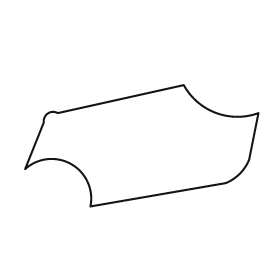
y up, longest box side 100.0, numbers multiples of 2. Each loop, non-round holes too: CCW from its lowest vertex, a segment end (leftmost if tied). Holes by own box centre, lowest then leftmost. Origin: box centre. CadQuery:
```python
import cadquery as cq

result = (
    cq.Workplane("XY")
    .moveTo(-22.0, -26.0)
    .lineTo(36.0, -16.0)
    .threePointArc((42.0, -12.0), (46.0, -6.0))
    .lineTo(50.0, 14.0)
    .threePointArc((32.0, 14.0), (18.0, 26.0))
    .lineTo(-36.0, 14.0)
    .threePointArc((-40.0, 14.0), (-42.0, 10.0))
    .lineTo(-50.0, -10.0)
    .threePointArc((-30.0, -8.0), (-22.0, -26.0))
    .close()
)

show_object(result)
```